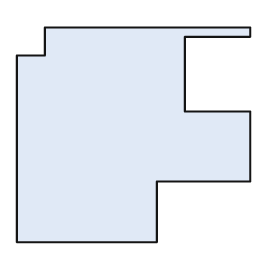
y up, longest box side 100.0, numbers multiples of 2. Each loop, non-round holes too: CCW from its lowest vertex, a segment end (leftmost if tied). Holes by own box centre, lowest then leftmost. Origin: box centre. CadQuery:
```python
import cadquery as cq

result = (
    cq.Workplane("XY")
    .moveTo(-50.0, -46.0)
    .lineTo(10.0, -46.0)
    .lineTo(10.0, -20.0)
    .lineTo(50.0, -20.0)
    .lineTo(50.0, 10.0)
    .lineTo(22.0, 10.0)
    .lineTo(22.0, 42.0)
    .lineTo(50.0, 42.0)
    .lineTo(50.0, 46.0)
    .lineTo(-38.0, 46.0)
    .lineTo(-38.0, 34.0)
    .lineTo(-50.0, 34.0)
    .close()
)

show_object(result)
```